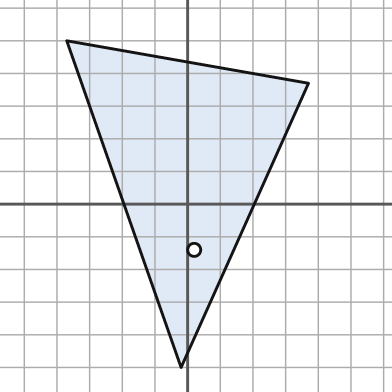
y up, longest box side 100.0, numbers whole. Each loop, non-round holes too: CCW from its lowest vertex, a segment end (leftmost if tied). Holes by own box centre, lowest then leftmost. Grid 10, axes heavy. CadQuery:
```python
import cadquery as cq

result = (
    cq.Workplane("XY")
    .moveTo(-2.0, -50.0)
    .lineTo(37.0, 37.0)
    .lineTo(-37.0, 50.0)
    .close()
    .moveTo(2.0, -14.0)
    .circle(2.0)
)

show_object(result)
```